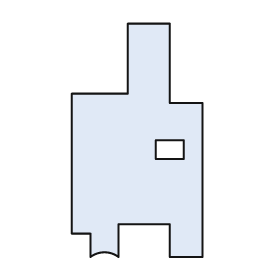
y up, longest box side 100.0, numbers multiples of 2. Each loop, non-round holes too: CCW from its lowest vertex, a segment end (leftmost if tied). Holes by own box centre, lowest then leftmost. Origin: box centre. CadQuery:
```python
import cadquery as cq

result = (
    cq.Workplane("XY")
    .moveTo(-20.0, -50.0)
    .threePointArc((-14.0, -48.0), (-8.0, -50.0))
    .lineTo(-8.0, -36.0)
    .lineTo(14.0, -36.0)
    .lineTo(14.0, -50.0)
    .lineTo(28.0, -50.0)
    .lineTo(28.0, 16.0)
    .lineTo(14.0, 16.0)
    .lineTo(14.0, 50.0)
    .lineTo(-4.0, 50.0)
    .lineTo(-4.0, 20.0)
    .lineTo(-28.0, 20.0)
    .lineTo(-28.0, -40.0)
    .lineTo(-20.0, -40.0)
    .close()
    .moveTo(8.0, -8.0)
    .lineTo(20.0, -8.0)
    .lineTo(20.0, 0.0)
    .lineTo(8.0, 0.0)
    .close()
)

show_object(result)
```